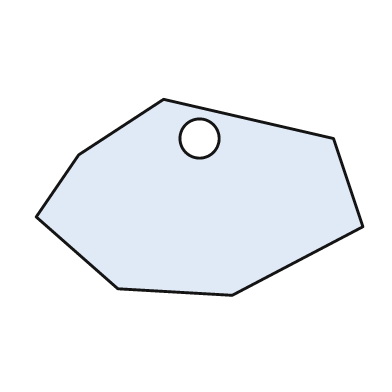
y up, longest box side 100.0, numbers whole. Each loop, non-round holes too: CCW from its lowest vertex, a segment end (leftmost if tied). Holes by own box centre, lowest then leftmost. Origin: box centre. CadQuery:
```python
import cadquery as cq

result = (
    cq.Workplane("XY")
    .moveTo(10.0, -30.0)
    .lineTo(50.0, -9.0)
    .lineTo(41.0, 18.0)
    .lineTo(-11.0, 30.0)
    .lineTo(-37.0, 13.0)
    .lineTo(-50.0, -6.0)
    .lineTo(-25.0, -28.0)
    .close()
    .moveTo(0.0, 18.0)
    .circle(6.0)
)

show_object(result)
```